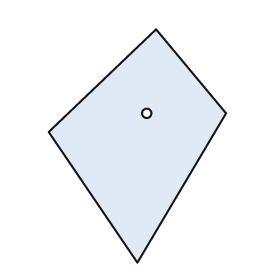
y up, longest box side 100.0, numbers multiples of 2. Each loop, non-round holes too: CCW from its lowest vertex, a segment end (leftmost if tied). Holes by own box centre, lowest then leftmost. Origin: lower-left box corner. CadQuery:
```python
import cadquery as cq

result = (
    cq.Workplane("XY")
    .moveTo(38.0, 0.0)
    .lineTo(76.0, 64.0)
    .lineTo(46.0, 100.0)
    .lineTo(0.0, 56.0)
    .close()
    .moveTo(42.0, 64.0)
    .circle(2.0)
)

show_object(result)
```